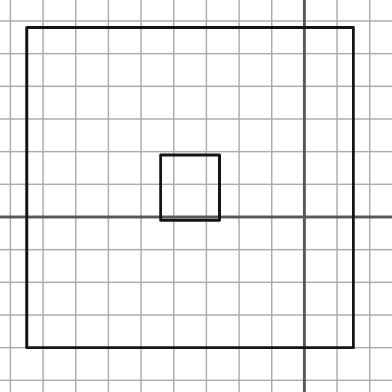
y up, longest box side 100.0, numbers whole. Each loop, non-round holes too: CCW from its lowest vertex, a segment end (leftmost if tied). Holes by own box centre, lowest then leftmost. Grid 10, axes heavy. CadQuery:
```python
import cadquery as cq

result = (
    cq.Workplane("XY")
    .moveTo(-85.0, -40.0)
    .lineTo(15.0, -40.0)
    .lineTo(15.0, 58.0)
    .lineTo(-85.0, 58.0)
    .close()
    .moveTo(-44.0, -1.0)
    .lineTo(-26.0, -1.0)
    .lineTo(-26.0, 19.0)
    .lineTo(-44.0, 19.0)
    .close()
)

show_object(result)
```